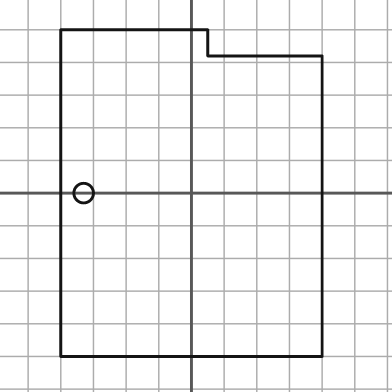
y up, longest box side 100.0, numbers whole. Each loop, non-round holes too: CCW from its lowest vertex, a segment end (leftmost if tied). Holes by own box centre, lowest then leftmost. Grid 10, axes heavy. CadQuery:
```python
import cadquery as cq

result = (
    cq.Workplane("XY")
    .moveTo(-40.0, -50.0)
    .lineTo(40.0, -50.0)
    .lineTo(40.0, 42.0)
    .lineTo(5.0, 42.0)
    .lineTo(5.0, 50.0)
    .lineTo(-40.0, 50.0)
    .close()
    .moveTo(-33.0, 0.0)
    .circle(3.0)
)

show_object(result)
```